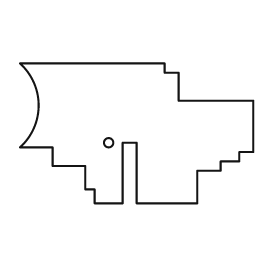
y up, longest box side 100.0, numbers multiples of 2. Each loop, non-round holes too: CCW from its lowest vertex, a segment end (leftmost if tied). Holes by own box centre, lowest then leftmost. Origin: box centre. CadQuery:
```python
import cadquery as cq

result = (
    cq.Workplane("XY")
    .moveTo(-18.0, -30.0)
    .lineTo(-6.0, -30.0)
    .lineTo(-6.0, -4.0)
    .lineTo(0.0, -4.0)
    .lineTo(0.0, -30.0)
    .lineTo(26.0, -30.0)
    .lineTo(26.0, -16.0)
    .lineTo(36.0, -16.0)
    .lineTo(36.0, -12.0)
    .lineTo(44.0, -12.0)
    .lineTo(44.0, -8.0)
    .lineTo(50.0, -8.0)
    .lineTo(50.0, 14.0)
    .lineTo(18.0, 14.0)
    .lineTo(18.0, 26.0)
    .lineTo(12.0, 26.0)
    .lineTo(12.0, 30.0)
    .lineTo(-50.0, 30.0)
    .threePointArc((-42.0, 12.0), (-50.0, -6.0))
    .lineTo(-36.0, -6.0)
    .lineTo(-36.0, -14.0)
    .lineTo(-22.0, -14.0)
    .lineTo(-22.0, -24.0)
    .lineTo(-18.0, -24.0)
    .close()
    .moveTo(-12.0, -4.0)
    .circle(2.0)
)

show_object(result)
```